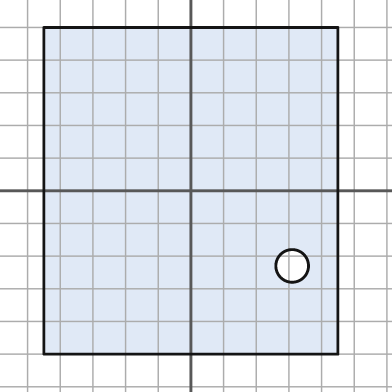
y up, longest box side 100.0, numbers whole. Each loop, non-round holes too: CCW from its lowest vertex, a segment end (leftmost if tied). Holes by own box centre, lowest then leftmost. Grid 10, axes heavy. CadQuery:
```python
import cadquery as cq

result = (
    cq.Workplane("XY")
    .moveTo(-45.0, -50.0)
    .lineTo(45.0, -50.0)
    .lineTo(45.0, 50.0)
    .lineTo(-45.0, 50.0)
    .close()
    .moveTo(31.0, -23.0)
    .circle(5.0)
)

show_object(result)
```